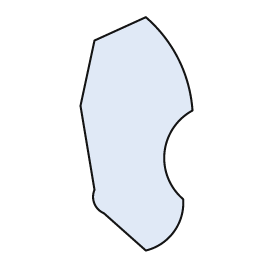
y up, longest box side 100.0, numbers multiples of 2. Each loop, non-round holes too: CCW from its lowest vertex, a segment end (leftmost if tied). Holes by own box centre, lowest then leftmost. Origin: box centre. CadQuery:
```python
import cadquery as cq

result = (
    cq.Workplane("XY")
    .moveTo(4.0, -50.0)
    .threePointArc((16.0, -42.0), (20.0, -28.0))
    .threePointArc((12.0, -8.0), (24.0, 10.0))
    .threePointArc((18.0, 32.0), (4.0, 50.0))
    .lineTo(-18.0, 40.0)
    .lineTo(-24.0, 12.0)
    .lineTo(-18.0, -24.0)
    .threePointArc((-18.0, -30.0), (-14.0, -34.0))
    .close()
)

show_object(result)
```